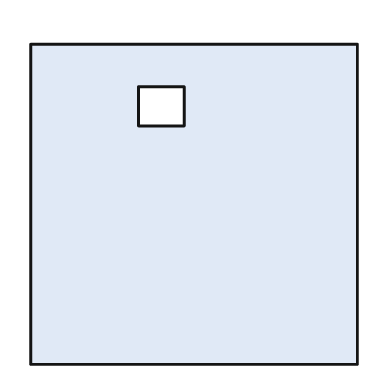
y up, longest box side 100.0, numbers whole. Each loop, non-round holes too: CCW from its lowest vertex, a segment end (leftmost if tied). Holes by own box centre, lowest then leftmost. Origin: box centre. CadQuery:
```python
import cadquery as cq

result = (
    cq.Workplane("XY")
    .moveTo(-50.0, -49.0)
    .lineTo(50.0, -49.0)
    .lineTo(50.0, 49.0)
    .lineTo(-50.0, 49.0)
    .close()
    .moveTo(-17.0, 24.0)
    .lineTo(-3.0, 24.0)
    .lineTo(-3.0, 36.0)
    .lineTo(-17.0, 36.0)
    .close()
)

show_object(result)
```